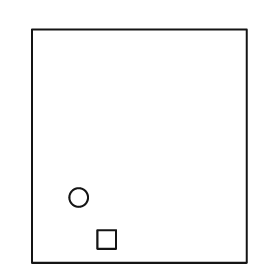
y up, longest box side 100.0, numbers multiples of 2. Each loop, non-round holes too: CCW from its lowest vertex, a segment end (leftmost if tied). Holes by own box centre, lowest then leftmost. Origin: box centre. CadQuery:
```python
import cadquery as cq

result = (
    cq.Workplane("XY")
    .moveTo(-46.0, -50.0)
    .lineTo(46.0, -50.0)
    .lineTo(46.0, 50.0)
    .lineTo(-46.0, 50.0)
    .close()
    .moveTo(-18.0, -44.0)
    .lineTo(-10.0, -44.0)
    .lineTo(-10.0, -36.0)
    .lineTo(-18.0, -36.0)
    .close()
    .moveTo(-26.0, -22.0)
    .circle(4.0)
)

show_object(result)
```